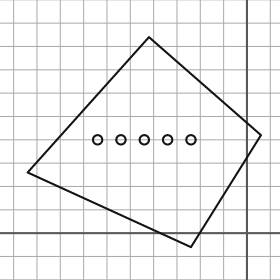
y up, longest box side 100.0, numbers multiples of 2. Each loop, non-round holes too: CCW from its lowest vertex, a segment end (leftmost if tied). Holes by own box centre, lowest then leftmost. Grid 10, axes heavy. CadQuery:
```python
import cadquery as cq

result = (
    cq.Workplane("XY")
    .moveTo(-24.0, -6.0)
    .lineTo(6.0, 42.0)
    .lineTo(-42.0, 84.0)
    .lineTo(-94.0, 26.0)
    .close()
    .moveTo(-64.0, 40.0)
    .circle(2.0)
    .moveTo(-54.0, 40.0)
    .circle(2.0)
    .moveTo(-44.0, 40.0)
    .circle(2.0)
    .moveTo(-34.0, 40.0)
    .circle(2.0)
    .moveTo(-24.0, 40.0)
    .circle(2.0)
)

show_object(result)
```